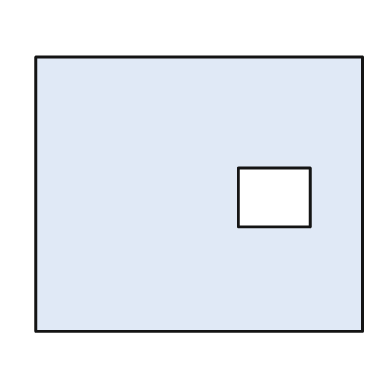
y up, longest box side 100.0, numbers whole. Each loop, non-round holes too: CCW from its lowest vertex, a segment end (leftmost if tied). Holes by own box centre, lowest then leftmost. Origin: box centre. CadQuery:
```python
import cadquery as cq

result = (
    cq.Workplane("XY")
    .moveTo(-50.0, -42.0)
    .lineTo(50.0, -42.0)
    .lineTo(50.0, 42.0)
    .lineTo(-50.0, 42.0)
    .close()
    .moveTo(12.0, -10.0)
    .lineTo(34.0, -10.0)
    .lineTo(34.0, 8.0)
    .lineTo(12.0, 8.0)
    .close()
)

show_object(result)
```